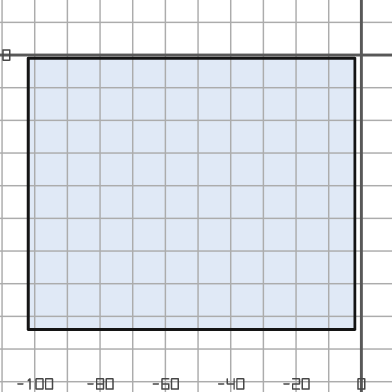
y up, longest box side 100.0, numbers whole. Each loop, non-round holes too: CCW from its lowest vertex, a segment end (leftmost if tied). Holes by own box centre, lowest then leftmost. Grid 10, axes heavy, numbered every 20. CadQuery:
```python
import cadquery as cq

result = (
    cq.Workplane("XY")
    .moveTo(-102.0, -84.0)
    .lineTo(-2.0, -84.0)
    .lineTo(-2.0, -1.0)
    .lineTo(-102.0, -1.0)
    .close()
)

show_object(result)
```